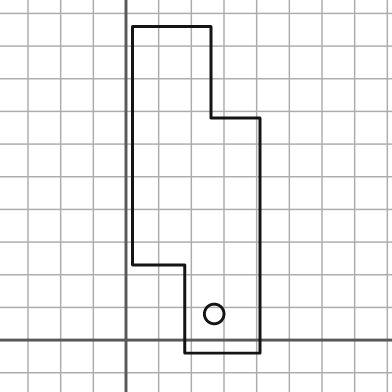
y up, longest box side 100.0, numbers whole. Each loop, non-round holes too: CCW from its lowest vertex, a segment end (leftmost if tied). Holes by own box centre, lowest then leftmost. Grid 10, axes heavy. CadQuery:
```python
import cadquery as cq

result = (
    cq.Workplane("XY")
    .moveTo(18.0, -4.0)
    .lineTo(41.0, -4.0)
    .lineTo(41.0, 68.0)
    .lineTo(26.0, 68.0)
    .lineTo(26.0, 96.0)
    .lineTo(2.0, 96.0)
    .lineTo(2.0, 23.0)
    .lineTo(18.0, 23.0)
    .close()
    .moveTo(27.0, 8.0)
    .circle(3.0)
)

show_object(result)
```